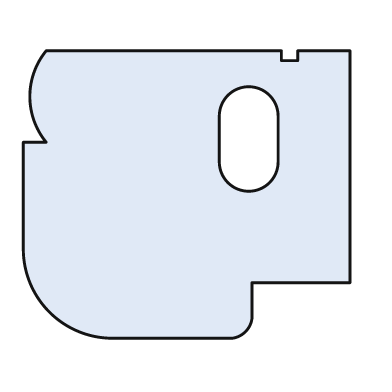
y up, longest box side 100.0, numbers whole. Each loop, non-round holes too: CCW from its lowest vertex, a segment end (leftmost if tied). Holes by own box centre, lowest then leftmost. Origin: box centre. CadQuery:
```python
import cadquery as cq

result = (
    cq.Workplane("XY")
    .moveTo(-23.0, -44.0)
    .lineTo(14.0, -44.0)
    .threePointArc((18.0, -42.0), (20.0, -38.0))
    .lineTo(20.0, -27.0)
    .lineTo(50.0, -27.0)
    .lineTo(50.0, 44.0)
    .lineTo(34.0, 44.0)
    .lineTo(34.0, 41.0)
    .lineTo(29.0, 41.0)
    .lineTo(29.0, 44.0)
    .lineTo(-43.0, 44.0)
    .threePointArc((-48.0, 30.0), (-43.0, 16.0))
    .lineTo(-50.0, 16.0)
    .lineTo(-50.0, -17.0)
    .threePointArc((-42.0, -36.0), (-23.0, -44.0))
    .close()
    .moveTo(10.0, 10.0)
    .threePointArc((19.0, 1.0), (28.0, 10.0))
    .lineTo(28.0, 24.0)
    .threePointArc((19.0, 33.0), (10.0, 24.0))
    .close()
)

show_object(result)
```